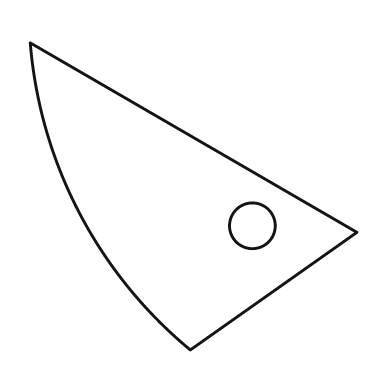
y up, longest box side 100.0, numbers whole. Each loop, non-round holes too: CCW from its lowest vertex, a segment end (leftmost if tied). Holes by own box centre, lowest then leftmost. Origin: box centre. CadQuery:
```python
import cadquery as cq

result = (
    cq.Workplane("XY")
    .moveTo(-1.0, -47.0)
    .lineTo(50.0, -11.0)
    .lineTo(-50.0, 47.0)
    .threePointArc((-35.0, -5.0), (-1.0, -47.0))
    .close()
    .moveTo(18.0, -9.0)
    .circle(7.0)
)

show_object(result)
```